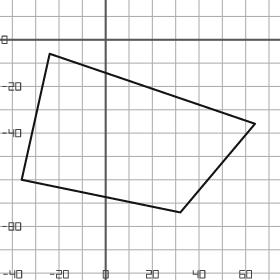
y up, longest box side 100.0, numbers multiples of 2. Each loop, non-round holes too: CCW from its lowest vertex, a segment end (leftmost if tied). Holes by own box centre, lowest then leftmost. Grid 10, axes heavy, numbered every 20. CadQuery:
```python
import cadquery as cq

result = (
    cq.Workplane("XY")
    .moveTo(32.0, -74.0)
    .lineTo(64.0, -36.0)
    .lineTo(-24.0, -6.0)
    .lineTo(-36.0, -60.0)
    .close()
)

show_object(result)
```